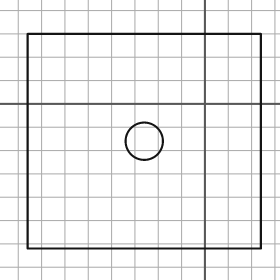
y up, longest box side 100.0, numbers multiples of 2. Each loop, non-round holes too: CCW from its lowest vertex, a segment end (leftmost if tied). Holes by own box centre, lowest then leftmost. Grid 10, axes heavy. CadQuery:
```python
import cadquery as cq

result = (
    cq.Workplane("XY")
    .moveTo(-76.0, -62.0)
    .lineTo(24.0, -62.0)
    .lineTo(24.0, 30.0)
    .lineTo(-76.0, 30.0)
    .close()
    .moveTo(-26.0, -16.0)
    .circle(8.0)
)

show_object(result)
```